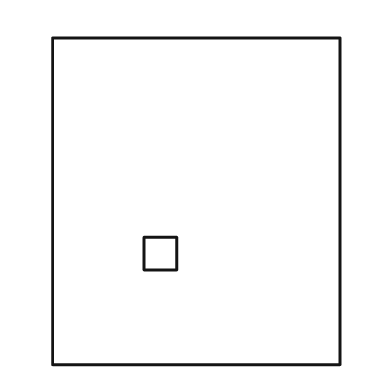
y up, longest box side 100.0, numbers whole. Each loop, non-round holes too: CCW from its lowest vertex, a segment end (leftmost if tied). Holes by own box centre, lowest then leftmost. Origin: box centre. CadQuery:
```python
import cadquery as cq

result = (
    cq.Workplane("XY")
    .moveTo(-44.0, -50.0)
    .lineTo(44.0, -50.0)
    .lineTo(44.0, 50.0)
    .lineTo(-44.0, 50.0)
    .close()
    .moveTo(-16.0, -21.0)
    .lineTo(-6.0, -21.0)
    .lineTo(-6.0, -11.0)
    .lineTo(-16.0, -11.0)
    .close()
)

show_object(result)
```